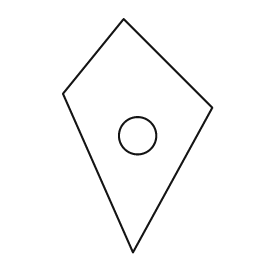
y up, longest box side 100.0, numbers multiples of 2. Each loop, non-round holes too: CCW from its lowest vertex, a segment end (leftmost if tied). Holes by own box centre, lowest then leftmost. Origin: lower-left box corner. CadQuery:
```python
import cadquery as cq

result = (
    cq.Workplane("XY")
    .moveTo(30.0, 0.0)
    .lineTo(64.0, 62.0)
    .lineTo(26.0, 100.0)
    .lineTo(0.0, 68.0)
    .close()
    .moveTo(32.0, 50.0)
    .circle(8.0)
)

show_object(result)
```